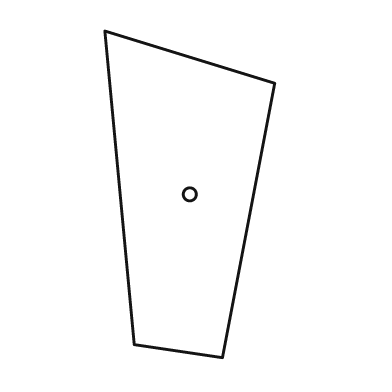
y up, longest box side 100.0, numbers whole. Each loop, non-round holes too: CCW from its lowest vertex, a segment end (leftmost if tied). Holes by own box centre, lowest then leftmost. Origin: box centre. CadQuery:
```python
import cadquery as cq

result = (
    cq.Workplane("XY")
    .moveTo(10.0, -50.0)
    .lineTo(26.0, 34.0)
    .lineTo(-26.0, 50.0)
    .lineTo(-17.0, -46.0)
    .close()
    .moveTo(0.0, 0.0)
    .circle(2.0)
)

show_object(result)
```